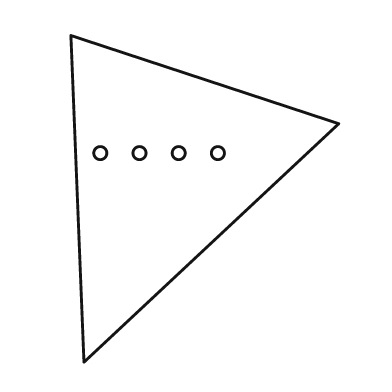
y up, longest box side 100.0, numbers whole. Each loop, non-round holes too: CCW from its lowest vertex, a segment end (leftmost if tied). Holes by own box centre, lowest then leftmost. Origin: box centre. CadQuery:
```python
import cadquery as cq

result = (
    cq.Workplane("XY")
    .moveTo(-37.0, -50.0)
    .lineTo(41.0, 23.0)
    .lineTo(-41.0, 50.0)
    .close()
    .moveTo(-32.0, 14.0)
    .circle(2.0)
    .moveTo(-20.0, 14.0)
    .circle(2.0)
    .moveTo(-8.0, 14.0)
    .circle(2.0)
    .moveTo(4.0, 14.0)
    .circle(2.0)
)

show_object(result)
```